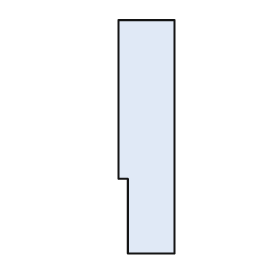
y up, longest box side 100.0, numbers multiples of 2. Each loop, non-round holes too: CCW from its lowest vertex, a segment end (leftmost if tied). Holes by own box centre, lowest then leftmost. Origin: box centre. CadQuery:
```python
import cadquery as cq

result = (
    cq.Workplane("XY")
    .moveTo(-8.0, -50.0)
    .lineTo(12.0, -50.0)
    .lineTo(12.0, 50.0)
    .lineTo(-12.0, 50.0)
    .lineTo(-12.0, -18.0)
    .lineTo(-8.0, -18.0)
    .close()
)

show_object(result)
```